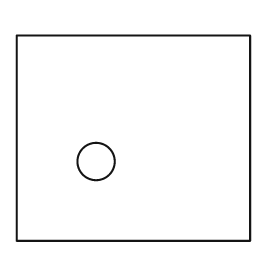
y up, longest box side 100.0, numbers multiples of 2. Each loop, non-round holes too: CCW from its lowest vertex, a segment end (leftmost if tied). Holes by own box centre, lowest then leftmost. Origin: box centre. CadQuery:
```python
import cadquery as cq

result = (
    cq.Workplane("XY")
    .moveTo(-50.0, -44.0)
    .lineTo(50.0, -44.0)
    .lineTo(50.0, 44.0)
    .lineTo(-50.0, 44.0)
    .close()
    .moveTo(-16.0, -10.0)
    .circle(8.0)
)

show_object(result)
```